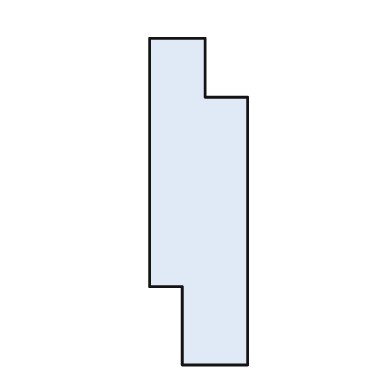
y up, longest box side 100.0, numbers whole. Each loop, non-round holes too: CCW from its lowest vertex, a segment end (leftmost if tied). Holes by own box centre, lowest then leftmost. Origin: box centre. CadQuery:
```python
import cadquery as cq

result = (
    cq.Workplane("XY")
    .moveTo(-5.0, -50.0)
    .lineTo(15.0, -50.0)
    .lineTo(15.0, 32.0)
    .lineTo(2.0, 32.0)
    .lineTo(2.0, 50.0)
    .lineTo(-15.0, 50.0)
    .lineTo(-15.0, -26.0)
    .lineTo(-5.0, -26.0)
    .close()
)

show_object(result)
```